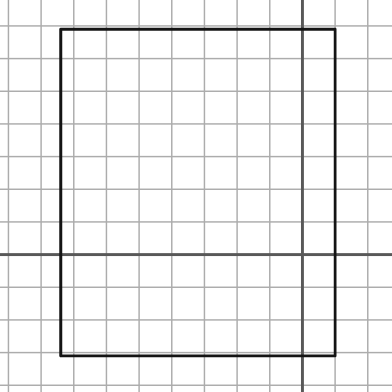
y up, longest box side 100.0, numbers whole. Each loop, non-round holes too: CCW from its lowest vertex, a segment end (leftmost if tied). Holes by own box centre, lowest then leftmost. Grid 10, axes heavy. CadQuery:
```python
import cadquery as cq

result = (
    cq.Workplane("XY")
    .moveTo(-74.0, -31.0)
    .lineTo(10.0, -31.0)
    .lineTo(10.0, 69.0)
    .lineTo(-74.0, 69.0)
    .close()
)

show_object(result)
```